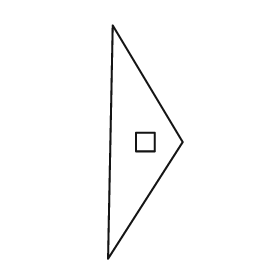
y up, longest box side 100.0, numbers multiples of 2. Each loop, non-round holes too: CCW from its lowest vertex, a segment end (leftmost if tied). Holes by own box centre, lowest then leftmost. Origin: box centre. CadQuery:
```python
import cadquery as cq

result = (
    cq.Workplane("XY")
    .moveTo(-16.0, -50.0)
    .lineTo(16.0, 0.0)
    .lineTo(-14.0, 50.0)
    .close()
    .moveTo(-4.0, -4.0)
    .lineTo(4.0, -4.0)
    .lineTo(4.0, 4.0)
    .lineTo(-4.0, 4.0)
    .close()
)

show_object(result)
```